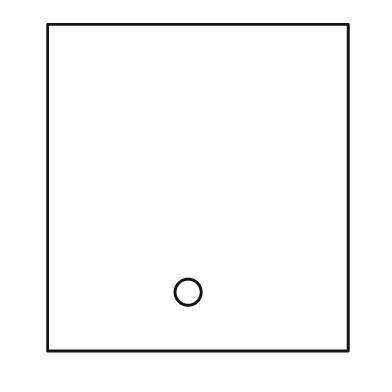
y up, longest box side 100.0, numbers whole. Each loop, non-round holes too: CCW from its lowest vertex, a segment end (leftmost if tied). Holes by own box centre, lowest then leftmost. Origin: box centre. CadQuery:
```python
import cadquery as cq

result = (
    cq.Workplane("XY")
    .moveTo(-46.0, -50.0)
    .lineTo(46.0, -50.0)
    .lineTo(46.0, 50.0)
    .lineTo(-46.0, 50.0)
    .close()
    .moveTo(-3.0, -32.0)
    .circle(4.0)
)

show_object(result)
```